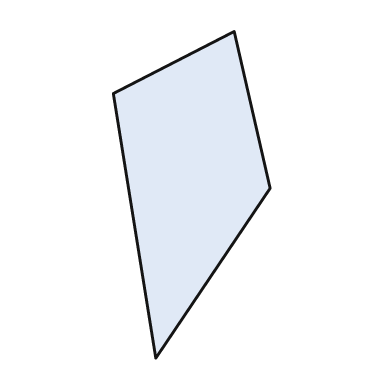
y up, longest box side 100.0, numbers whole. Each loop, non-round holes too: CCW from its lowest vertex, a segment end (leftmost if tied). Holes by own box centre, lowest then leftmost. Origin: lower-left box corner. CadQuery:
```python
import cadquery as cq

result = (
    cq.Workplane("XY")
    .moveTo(13.0, 0.0)
    .lineTo(48.0, 52.0)
    .lineTo(37.0, 100.0)
    .lineTo(0.0, 81.0)
    .close()
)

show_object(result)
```